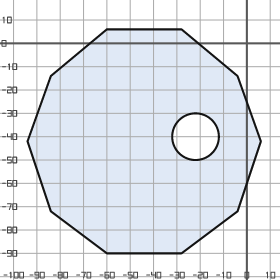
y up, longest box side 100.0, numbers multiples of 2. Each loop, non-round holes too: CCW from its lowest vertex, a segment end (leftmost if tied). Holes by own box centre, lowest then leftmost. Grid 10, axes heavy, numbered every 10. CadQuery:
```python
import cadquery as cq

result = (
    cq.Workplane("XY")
    .moveTo(-60.0, -90.0)
    .lineTo(-28.0, -90.0)
    .lineTo(-4.0, -72.0)
    .lineTo(6.0, -42.0)
    .lineTo(-4.0, -14.0)
    .lineTo(-28.0, 6.0)
    .lineTo(-60.0, 6.0)
    .lineTo(-84.0, -14.0)
    .lineTo(-94.0, -42.0)
    .lineTo(-84.0, -72.0)
    .close()
    .moveTo(-22.0, -40.0)
    .circle(10.0)
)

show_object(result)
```